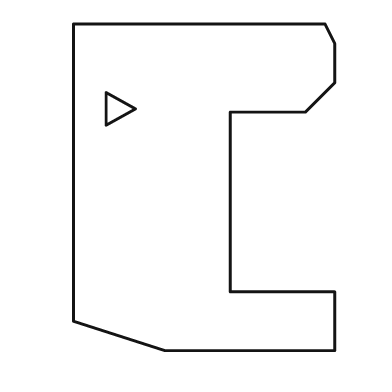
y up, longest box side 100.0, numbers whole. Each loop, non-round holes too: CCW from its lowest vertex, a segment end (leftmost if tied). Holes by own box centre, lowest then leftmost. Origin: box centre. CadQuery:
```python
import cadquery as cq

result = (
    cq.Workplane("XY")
    .moveTo(-12.0, -50.0)
    .lineTo(40.0, -50.0)
    .lineTo(40.0, -32.0)
    .lineTo(8.0, -32.0)
    .lineTo(8.0, 23.0)
    .lineTo(31.0, 23.0)
    .lineTo(40.0, 32.0)
    .lineTo(40.0, 44.0)
    .lineTo(37.0, 50.0)
    .lineTo(-40.0, 50.0)
    .lineTo(-40.0, -41.0)
    .close()
    .moveTo(-30.0, 19.0)
    .lineTo(-21.0, 24.0)
    .lineTo(-30.0, 29.0)
    .close()
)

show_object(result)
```